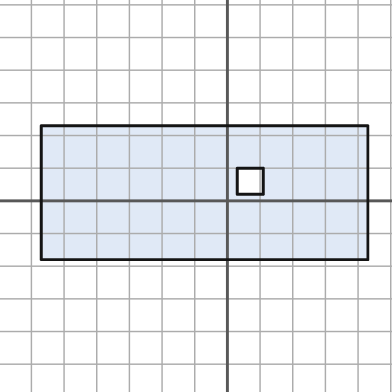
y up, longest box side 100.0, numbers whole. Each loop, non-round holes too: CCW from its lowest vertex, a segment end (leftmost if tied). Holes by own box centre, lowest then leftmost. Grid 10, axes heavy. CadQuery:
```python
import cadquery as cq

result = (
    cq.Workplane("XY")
    .moveTo(-57.0, -18.0)
    .lineTo(43.0, -18.0)
    .lineTo(43.0, 23.0)
    .lineTo(-57.0, 23.0)
    .close()
    .moveTo(3.0, 2.0)
    .lineTo(11.0, 2.0)
    .lineTo(11.0, 10.0)
    .lineTo(3.0, 10.0)
    .close()
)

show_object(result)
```